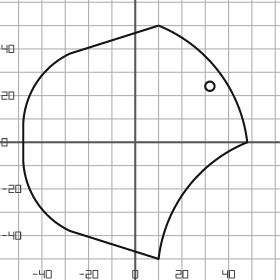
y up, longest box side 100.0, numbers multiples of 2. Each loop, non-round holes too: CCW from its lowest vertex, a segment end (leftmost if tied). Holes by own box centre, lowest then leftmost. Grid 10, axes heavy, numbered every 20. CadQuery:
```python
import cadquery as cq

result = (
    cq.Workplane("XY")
    .moveTo(10.0, -50.0)
    .threePointArc((22.0, -20.0), (48.0, 0.0))
    .threePointArc((36.0, 30.0), (10.0, 50.0))
    .lineTo(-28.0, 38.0)
    .threePointArc((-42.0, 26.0), (-48.0, 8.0))
    .lineTo(-48.0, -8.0)
    .threePointArc((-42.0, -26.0), (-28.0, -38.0))
    .close()
    .moveTo(32.0, 24.0)
    .circle(2.0)
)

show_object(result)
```